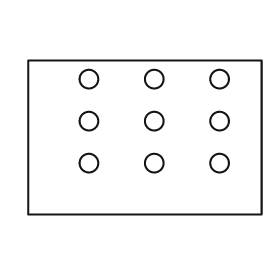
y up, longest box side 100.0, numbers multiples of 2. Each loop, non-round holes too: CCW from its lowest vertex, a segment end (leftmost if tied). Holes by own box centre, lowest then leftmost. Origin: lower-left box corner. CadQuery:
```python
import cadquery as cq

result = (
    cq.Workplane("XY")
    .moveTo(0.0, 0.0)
    .lineTo(100.0, 0.0)
    .lineTo(100.0, 66.0)
    .lineTo(0.0, 66.0)
    .close()
    .moveTo(26.0, 22.0)
    .circle(4.0)
    .moveTo(54.0, 22.0)
    .circle(4.0)
    .moveTo(82.0, 22.0)
    .circle(4.0)
    .moveTo(26.0, 40.0)
    .circle(4.0)
    .moveTo(54.0, 40.0)
    .circle(4.0)
    .moveTo(82.0, 40.0)
    .circle(4.0)
    .moveTo(26.0, 58.0)
    .circle(4.0)
    .moveTo(54.0, 58.0)
    .circle(4.0)
    .moveTo(82.0, 58.0)
    .circle(4.0)
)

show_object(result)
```